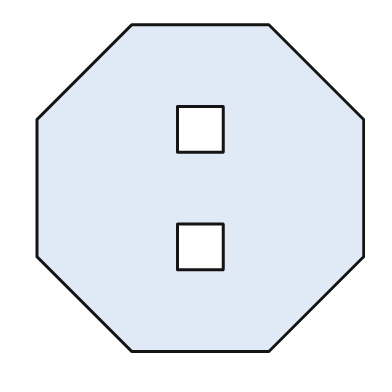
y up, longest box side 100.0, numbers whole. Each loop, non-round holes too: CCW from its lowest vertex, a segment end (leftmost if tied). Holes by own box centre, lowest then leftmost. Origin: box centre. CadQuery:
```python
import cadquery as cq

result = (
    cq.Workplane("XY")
    .moveTo(-21.0, -50.0)
    .lineTo(21.0, -50.0)
    .lineTo(50.0, -21.0)
    .lineTo(50.0, 21.0)
    .lineTo(21.0, 50.0)
    .lineTo(-21.0, 50.0)
    .lineTo(-50.0, 21.0)
    .lineTo(-50.0, -21.0)
    .close()
    .moveTo(-7.0, -25.0)
    .lineTo(7.0, -25.0)
    .lineTo(7.0, -11.0)
    .lineTo(-7.0, -11.0)
    .close()
    .moveTo(-7.0, 11.0)
    .lineTo(7.0, 11.0)
    .lineTo(7.0, 25.0)
    .lineTo(-7.0, 25.0)
    .close()
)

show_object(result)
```